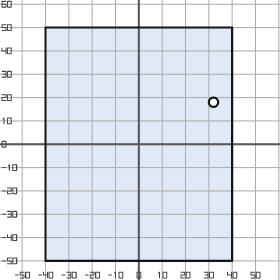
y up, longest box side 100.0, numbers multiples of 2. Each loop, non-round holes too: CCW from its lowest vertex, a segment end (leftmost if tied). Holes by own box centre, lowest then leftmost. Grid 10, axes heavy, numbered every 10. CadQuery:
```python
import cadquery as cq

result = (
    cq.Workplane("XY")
    .moveTo(-40.0, -50.0)
    .lineTo(40.0, -50.0)
    .lineTo(40.0, 50.0)
    .lineTo(-40.0, 50.0)
    .close()
    .moveTo(32.0, 18.0)
    .circle(2.0)
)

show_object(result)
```